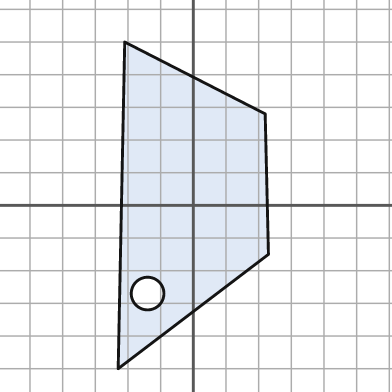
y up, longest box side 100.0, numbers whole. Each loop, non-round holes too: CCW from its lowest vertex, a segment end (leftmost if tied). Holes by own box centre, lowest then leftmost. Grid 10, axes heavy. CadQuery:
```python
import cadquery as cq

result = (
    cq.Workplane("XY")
    .moveTo(-23.0, -50.0)
    .lineTo(23.0, -15.0)
    .lineTo(22.0, 28.0)
    .lineTo(-21.0, 50.0)
    .close()
    .moveTo(-14.0, -27.0)
    .circle(5.0)
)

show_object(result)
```